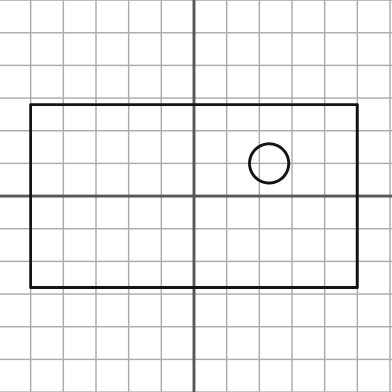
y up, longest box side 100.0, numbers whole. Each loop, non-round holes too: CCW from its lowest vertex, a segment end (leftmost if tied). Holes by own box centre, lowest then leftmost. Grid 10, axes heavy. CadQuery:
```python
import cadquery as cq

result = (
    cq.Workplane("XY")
    .moveTo(-50.0, -28.0)
    .lineTo(50.0, -28.0)
    .lineTo(50.0, 28.0)
    .lineTo(-50.0, 28.0)
    .close()
    .moveTo(23.0, 10.0)
    .circle(6.0)
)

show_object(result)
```